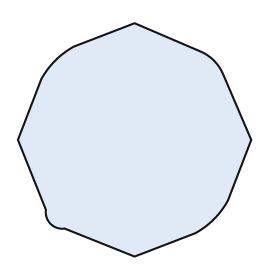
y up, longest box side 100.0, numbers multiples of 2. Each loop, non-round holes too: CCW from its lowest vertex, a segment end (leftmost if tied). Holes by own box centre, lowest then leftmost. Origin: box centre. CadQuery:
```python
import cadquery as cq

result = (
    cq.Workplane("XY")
    .moveTo(0.0, -50.0)
    .lineTo(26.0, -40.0)
    .threePointArc((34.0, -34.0), (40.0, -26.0))
    .lineTo(50.0, 0.0)
    .lineTo(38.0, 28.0)
    .threePointArc((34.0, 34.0), (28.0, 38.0))
    .lineTo(0.0, 50.0)
    .lineTo(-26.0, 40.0)
    .threePointArc((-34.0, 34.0), (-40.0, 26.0))
    .lineTo(-50.0, 0.0)
    .lineTo(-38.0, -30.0)
    .threePointArc((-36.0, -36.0), (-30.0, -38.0))
    .close()
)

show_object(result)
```